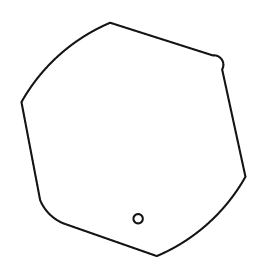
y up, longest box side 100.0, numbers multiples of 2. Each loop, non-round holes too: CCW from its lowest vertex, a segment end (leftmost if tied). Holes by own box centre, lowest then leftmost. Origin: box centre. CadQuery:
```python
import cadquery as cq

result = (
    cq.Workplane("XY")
    .moveTo(10.0, -50.0)
    .threePointArc((32.0, -36.0), (48.0, -16.0))
    .lineTo(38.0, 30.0)
    .threePointArc((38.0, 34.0), (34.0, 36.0))
    .lineTo(-10.0, 50.0)
    .threePointArc((-32.0, 36.0), (-48.0, 16.0))
    .lineTo(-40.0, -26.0)
    .threePointArc((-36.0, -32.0), (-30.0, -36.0))
    .close()
    .moveTo(2.0, -34.0)
    .circle(2.0)
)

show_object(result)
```